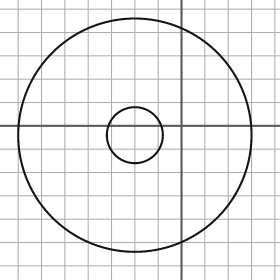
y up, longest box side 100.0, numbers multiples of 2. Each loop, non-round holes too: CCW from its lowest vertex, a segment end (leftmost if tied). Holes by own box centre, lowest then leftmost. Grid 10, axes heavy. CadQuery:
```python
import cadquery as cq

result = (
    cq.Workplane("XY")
    .moveTo(-20.0, -4.0)
    .circle(50.0)
    .moveTo(-20.0, -4.0)
    .circle(12.0)
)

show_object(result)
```